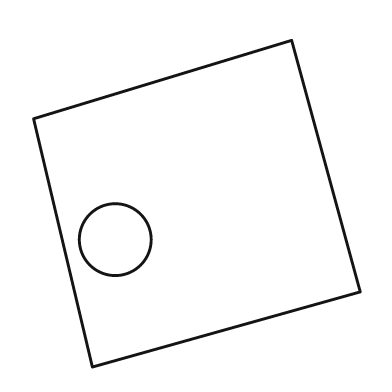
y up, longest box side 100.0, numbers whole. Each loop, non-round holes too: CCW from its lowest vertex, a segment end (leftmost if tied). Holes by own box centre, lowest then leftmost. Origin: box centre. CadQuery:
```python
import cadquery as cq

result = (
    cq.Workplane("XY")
    .moveTo(-32.0, -50.0)
    .lineTo(50.0, -27.0)
    .lineTo(29.0, 50.0)
    .lineTo(-50.0, 26.0)
    .close()
    .moveTo(-25.0, -11.0)
    .circle(11.0)
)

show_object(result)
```